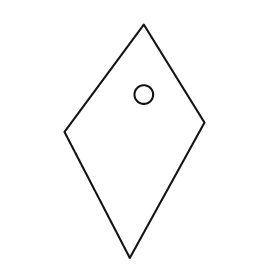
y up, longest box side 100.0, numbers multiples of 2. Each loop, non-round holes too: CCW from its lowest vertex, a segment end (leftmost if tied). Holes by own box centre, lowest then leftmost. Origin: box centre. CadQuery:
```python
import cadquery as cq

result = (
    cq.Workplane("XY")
    .moveTo(-2.0, -50.0)
    .lineTo(30.0, 8.0)
    .lineTo(4.0, 50.0)
    .lineTo(-30.0, 4.0)
    .close()
    .moveTo(4.0, 20.0)
    .circle(4.0)
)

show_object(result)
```